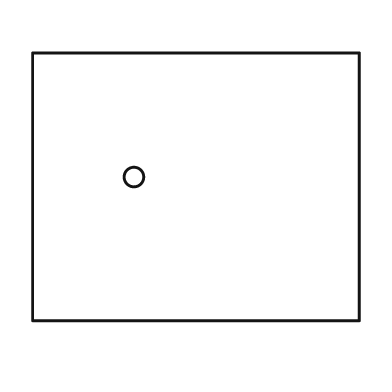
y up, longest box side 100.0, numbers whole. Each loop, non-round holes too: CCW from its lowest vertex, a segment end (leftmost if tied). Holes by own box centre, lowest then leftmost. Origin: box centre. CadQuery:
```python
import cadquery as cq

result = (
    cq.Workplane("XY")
    .moveTo(-50.0, -41.0)
    .lineTo(50.0, -41.0)
    .lineTo(50.0, 41.0)
    .lineTo(-50.0, 41.0)
    .close()
    .moveTo(-19.0, 3.0)
    .circle(3.0)
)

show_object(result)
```